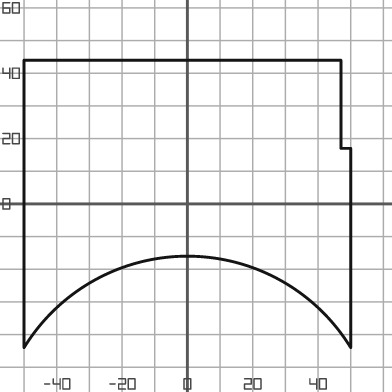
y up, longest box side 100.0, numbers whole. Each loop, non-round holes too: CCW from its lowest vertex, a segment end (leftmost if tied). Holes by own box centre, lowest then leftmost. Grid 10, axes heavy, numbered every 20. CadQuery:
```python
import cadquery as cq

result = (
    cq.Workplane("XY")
    .moveTo(-50.0, -44.0)
    .threePointArc((0.0, -16.0), (50.0, -44.0))
    .lineTo(50.0, 17.0)
    .lineTo(47.0, 17.0)
    .lineTo(47.0, 44.0)
    .lineTo(-50.0, 44.0)
    .close()
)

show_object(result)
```